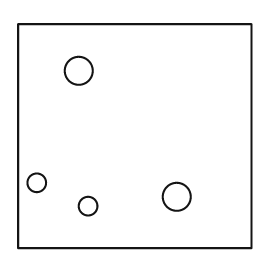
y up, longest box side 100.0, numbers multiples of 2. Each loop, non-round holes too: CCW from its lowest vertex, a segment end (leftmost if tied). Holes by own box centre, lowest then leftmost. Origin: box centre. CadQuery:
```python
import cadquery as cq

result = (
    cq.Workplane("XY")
    .moveTo(-50.0, -48.0)
    .lineTo(50.0, -48.0)
    .lineTo(50.0, 48.0)
    .lineTo(-50.0, 48.0)
    .close()
    .moveTo(-20.0, -30.0)
    .circle(4.0)
    .moveTo(18.0, -26.0)
    .circle(6.0)
    .moveTo(-42.0, -20.0)
    .circle(4.0)
    .moveTo(-24.0, 28.0)
    .circle(6.0)
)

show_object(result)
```